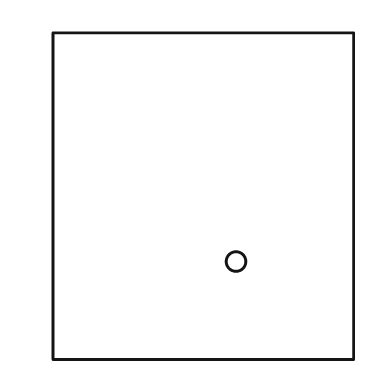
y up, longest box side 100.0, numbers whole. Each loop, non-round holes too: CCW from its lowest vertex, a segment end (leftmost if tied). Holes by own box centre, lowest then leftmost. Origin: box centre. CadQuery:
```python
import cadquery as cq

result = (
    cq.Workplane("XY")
    .moveTo(-46.0, -50.0)
    .lineTo(46.0, -50.0)
    .lineTo(46.0, 50.0)
    .lineTo(-46.0, 50.0)
    .close()
    .moveTo(10.0, -20.0)
    .circle(3.0)
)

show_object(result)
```